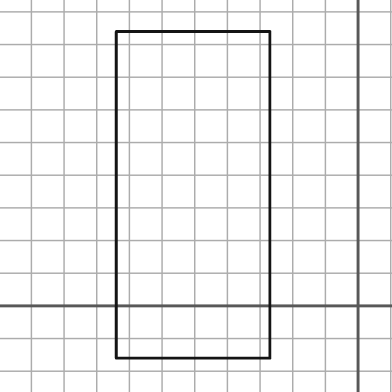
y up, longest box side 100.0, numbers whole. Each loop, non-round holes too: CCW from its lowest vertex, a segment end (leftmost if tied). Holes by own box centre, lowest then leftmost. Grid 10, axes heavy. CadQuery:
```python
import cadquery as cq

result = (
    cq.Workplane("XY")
    .moveTo(-74.0, -16.0)
    .lineTo(-27.0, -16.0)
    .lineTo(-27.0, 84.0)
    .lineTo(-74.0, 84.0)
    .close()
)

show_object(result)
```